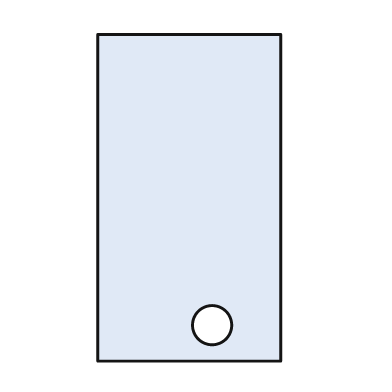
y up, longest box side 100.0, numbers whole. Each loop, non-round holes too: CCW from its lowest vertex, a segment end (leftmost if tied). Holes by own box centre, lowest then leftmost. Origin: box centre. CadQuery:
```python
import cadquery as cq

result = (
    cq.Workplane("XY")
    .moveTo(-28.0, -50.0)
    .lineTo(28.0, -50.0)
    .lineTo(28.0, 50.0)
    .lineTo(-28.0, 50.0)
    .close()
    .moveTo(7.0, -39.0)
    .circle(6.0)
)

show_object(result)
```